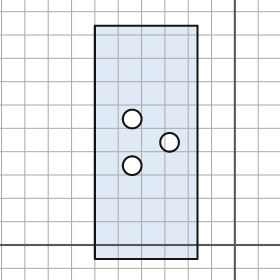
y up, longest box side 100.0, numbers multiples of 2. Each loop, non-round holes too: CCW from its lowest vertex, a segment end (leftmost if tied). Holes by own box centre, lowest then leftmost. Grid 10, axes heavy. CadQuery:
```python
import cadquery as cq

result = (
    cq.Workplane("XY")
    .moveTo(-60.0, -6.0)
    .lineTo(-16.0, -6.0)
    .lineTo(-16.0, 94.0)
    .lineTo(-60.0, 94.0)
    .close()
    .moveTo(-44.0, 34.0)
    .circle(4.0)
    .moveTo(-28.0, 44.0)
    .circle(4.0)
    .moveTo(-44.0, 54.0)
    .circle(4.0)
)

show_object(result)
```